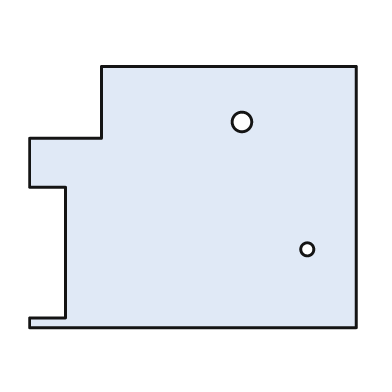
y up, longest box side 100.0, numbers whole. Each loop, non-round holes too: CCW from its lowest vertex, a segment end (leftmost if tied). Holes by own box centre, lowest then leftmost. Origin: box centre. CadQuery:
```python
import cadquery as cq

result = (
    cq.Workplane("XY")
    .moveTo(-50.0, -40.0)
    .lineTo(50.0, -40.0)
    .lineTo(50.0, 40.0)
    .lineTo(-28.0, 40.0)
    .lineTo(-28.0, 18.0)
    .lineTo(-50.0, 18.0)
    .lineTo(-50.0, 3.0)
    .lineTo(-39.0, 3.0)
    .lineTo(-39.0, -37.0)
    .lineTo(-50.0, -37.0)
    .close()
    .moveTo(35.0, -16.0)
    .circle(2.0)
    .moveTo(15.0, 23.0)
    .circle(3.0)
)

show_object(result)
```